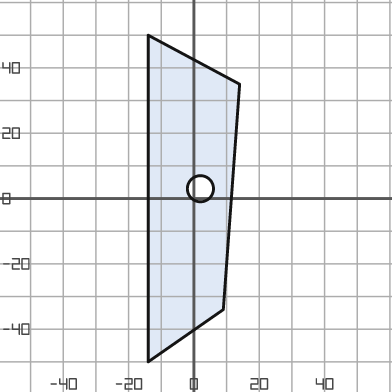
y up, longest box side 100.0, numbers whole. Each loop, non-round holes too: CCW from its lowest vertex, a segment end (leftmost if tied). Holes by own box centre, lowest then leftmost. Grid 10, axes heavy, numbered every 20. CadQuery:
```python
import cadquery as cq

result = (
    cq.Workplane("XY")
    .moveTo(-14.0, -50.0)
    .lineTo(9.0, -34.0)
    .lineTo(14.0, 35.0)
    .lineTo(-14.0, 50.0)
    .close()
    .moveTo(2.0, 3.0)
    .circle(4.0)
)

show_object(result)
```